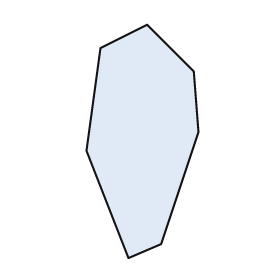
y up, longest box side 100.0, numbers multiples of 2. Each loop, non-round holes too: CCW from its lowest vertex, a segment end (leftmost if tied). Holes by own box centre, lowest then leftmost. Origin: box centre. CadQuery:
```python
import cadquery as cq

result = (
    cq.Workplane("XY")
    .moveTo(-6.0, -50.0)
    .lineTo(8.0, -44.0)
    .lineTo(24.0, 4.0)
    .lineTo(22.0, 30.0)
    .lineTo(2.0, 50.0)
    .lineTo(-18.0, 40.0)
    .lineTo(-24.0, -4.0)
    .close()
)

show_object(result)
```